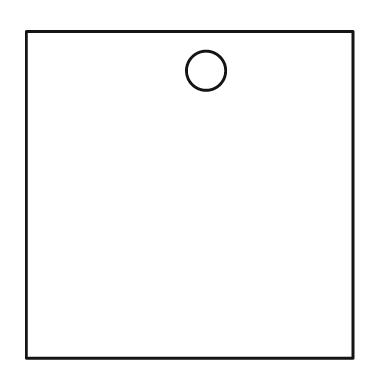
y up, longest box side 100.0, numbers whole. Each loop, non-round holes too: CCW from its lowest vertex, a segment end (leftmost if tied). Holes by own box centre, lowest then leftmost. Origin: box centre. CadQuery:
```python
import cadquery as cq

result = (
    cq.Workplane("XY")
    .moveTo(-50.0, -50.0)
    .lineTo(50.0, -50.0)
    .lineTo(50.0, 50.0)
    .lineTo(-50.0, 50.0)
    .close()
    .moveTo(5.0, 38.0)
    .circle(6.0)
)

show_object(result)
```